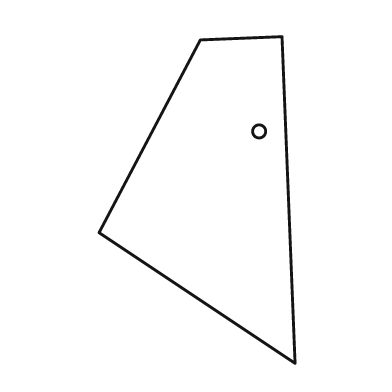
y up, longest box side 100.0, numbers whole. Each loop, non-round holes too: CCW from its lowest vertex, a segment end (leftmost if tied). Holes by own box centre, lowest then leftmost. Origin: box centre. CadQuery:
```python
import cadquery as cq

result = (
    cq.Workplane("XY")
    .moveTo(30.0, -50.0)
    .lineTo(26.0, 50.0)
    .lineTo(1.0, 49.0)
    .lineTo(-30.0, -10.0)
    .close()
    .moveTo(19.0, 21.0)
    .circle(2.0)
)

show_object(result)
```